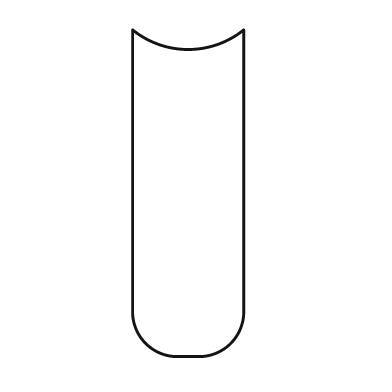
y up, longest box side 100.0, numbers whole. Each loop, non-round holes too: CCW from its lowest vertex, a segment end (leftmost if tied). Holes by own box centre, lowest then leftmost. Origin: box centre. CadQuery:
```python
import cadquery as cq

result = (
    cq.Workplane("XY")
    .moveTo(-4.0, -50.0)
    .lineTo(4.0, -50.0)
    .threePointArc((13.0, -46.0), (17.0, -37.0))
    .lineTo(17.0, 50.0)
    .threePointArc((0.0, 44.0), (-17.0, 50.0))
    .lineTo(-17.0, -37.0)
    .threePointArc((-13.0, -46.0), (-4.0, -50.0))
    .close()
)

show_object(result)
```